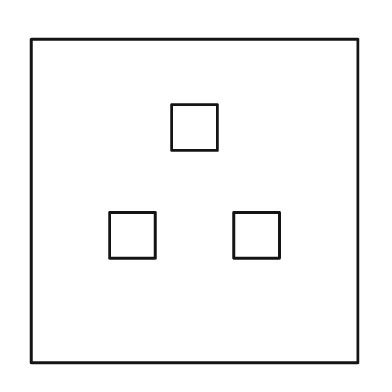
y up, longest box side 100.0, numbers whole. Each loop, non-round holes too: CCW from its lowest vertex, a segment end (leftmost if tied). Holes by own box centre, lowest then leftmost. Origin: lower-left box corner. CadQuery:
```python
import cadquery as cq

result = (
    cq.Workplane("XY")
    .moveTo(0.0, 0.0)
    .lineTo(100.0, 0.0)
    .lineTo(100.0, 99.0)
    .lineTo(0.0, 99.0)
    .close()
    .moveTo(24.0, 32.0)
    .lineTo(38.0, 32.0)
    .lineTo(38.0, 46.0)
    .lineTo(24.0, 46.0)
    .close()
    .moveTo(62.0, 32.0)
    .lineTo(76.0, 32.0)
    .lineTo(76.0, 46.0)
    .lineTo(62.0, 46.0)
    .close()
    .moveTo(43.0, 65.0)
    .lineTo(57.0, 65.0)
    .lineTo(57.0, 79.0)
    .lineTo(43.0, 79.0)
    .close()
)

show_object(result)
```